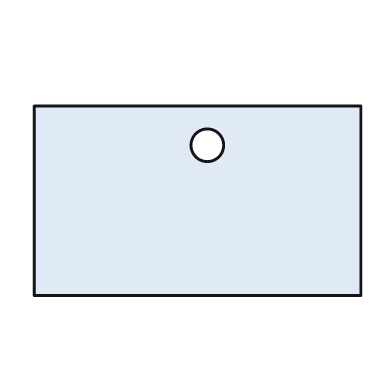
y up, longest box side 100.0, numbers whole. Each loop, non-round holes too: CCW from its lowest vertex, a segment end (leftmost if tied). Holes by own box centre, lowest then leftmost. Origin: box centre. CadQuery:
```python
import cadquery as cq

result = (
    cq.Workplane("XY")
    .moveTo(-50.0, -29.0)
    .lineTo(50.0, -29.0)
    .lineTo(50.0, 29.0)
    .lineTo(-50.0, 29.0)
    .close()
    .moveTo(3.0, 17.0)
    .circle(5.0)
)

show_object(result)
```